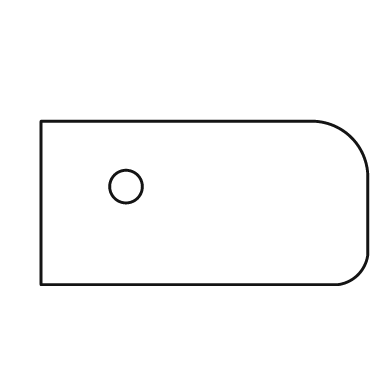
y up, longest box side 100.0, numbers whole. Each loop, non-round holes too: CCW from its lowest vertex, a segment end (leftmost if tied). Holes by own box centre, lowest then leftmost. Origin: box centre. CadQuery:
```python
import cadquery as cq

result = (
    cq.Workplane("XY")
    .moveTo(-50.0, -25.0)
    .lineTo(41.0, -25.0)
    .threePointArc((47.0, -22.0), (50.0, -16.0))
    .lineTo(50.0, 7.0)
    .threePointArc((45.0, 20.0), (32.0, 25.0))
    .lineTo(-50.0, 25.0)
    .close()
    .moveTo(-24.0, 5.0)
    .circle(5.0)
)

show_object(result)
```